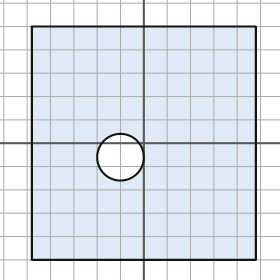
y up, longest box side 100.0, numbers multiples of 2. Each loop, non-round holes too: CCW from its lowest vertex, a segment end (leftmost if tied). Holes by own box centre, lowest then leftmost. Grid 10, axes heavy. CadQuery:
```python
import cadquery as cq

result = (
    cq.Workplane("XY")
    .moveTo(-48.0, -50.0)
    .lineTo(48.0, -50.0)
    .lineTo(48.0, 50.0)
    .lineTo(-48.0, 50.0)
    .close()
    .moveTo(-10.0, -6.0)
    .circle(10.0)
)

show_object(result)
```